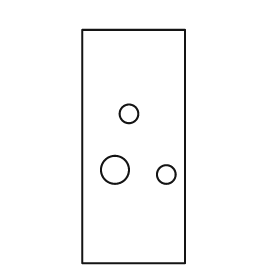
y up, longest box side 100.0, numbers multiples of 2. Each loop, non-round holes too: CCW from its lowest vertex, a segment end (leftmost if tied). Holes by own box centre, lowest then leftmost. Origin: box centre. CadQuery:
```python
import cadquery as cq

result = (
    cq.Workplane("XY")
    .moveTo(-22.0, -50.0)
    .lineTo(22.0, -50.0)
    .lineTo(22.0, 50.0)
    .lineTo(-22.0, 50.0)
    .close()
    .moveTo(14.0, -12.0)
    .circle(4.0)
    .moveTo(-8.0, -10.0)
    .circle(6.0)
    .moveTo(-2.0, 14.0)
    .circle(4.0)
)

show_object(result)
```